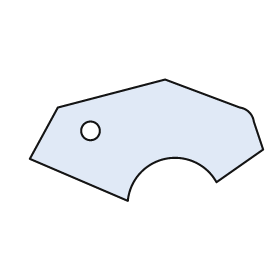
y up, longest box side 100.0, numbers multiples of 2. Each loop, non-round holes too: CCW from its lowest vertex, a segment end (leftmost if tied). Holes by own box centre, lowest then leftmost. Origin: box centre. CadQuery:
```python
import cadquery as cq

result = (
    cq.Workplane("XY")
    .moveTo(-8.0, -26.0)
    .threePointArc((8.0, -8.0), (30.0, -18.0))
    .lineTo(50.0, -4.0)
    .lineTo(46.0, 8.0)
    .threePointArc((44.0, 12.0), (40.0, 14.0))
    .lineTo(8.0, 26.0)
    .lineTo(-38.0, 14.0)
    .lineTo(-50.0, -8.0)
    .close()
    .moveTo(-24.0, 4.0)
    .circle(4.0)
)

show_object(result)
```